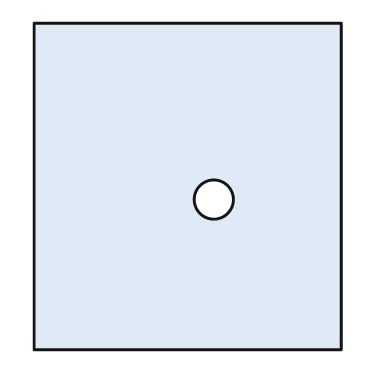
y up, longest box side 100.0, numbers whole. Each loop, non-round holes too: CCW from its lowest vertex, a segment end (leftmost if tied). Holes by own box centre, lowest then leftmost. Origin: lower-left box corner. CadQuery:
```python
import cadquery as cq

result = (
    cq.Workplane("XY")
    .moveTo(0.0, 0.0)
    .lineTo(94.0, 0.0)
    .lineTo(94.0, 100.0)
    .lineTo(0.0, 100.0)
    .close()
    .moveTo(55.0, 46.0)
    .circle(6.0)
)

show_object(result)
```